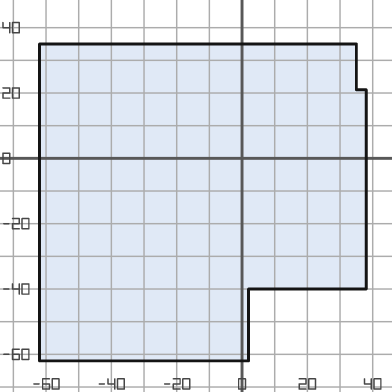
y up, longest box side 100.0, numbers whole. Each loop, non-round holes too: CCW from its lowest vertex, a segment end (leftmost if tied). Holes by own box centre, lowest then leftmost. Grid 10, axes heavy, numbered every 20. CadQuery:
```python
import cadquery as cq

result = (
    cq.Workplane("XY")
    .moveTo(-62.0, -62.0)
    .lineTo(2.0, -62.0)
    .lineTo(2.0, -40.0)
    .lineTo(38.0, -40.0)
    .lineTo(38.0, 21.0)
    .lineTo(35.0, 21.0)
    .lineTo(35.0, 35.0)
    .lineTo(-62.0, 35.0)
    .close()
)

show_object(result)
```